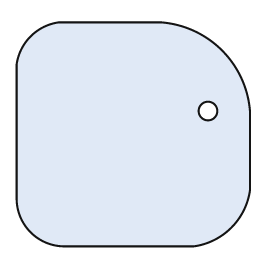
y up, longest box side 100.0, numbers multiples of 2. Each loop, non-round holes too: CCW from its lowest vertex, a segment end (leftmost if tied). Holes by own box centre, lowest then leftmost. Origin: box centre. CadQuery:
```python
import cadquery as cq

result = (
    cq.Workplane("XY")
    .moveTo(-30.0, -48.0)
    .lineTo(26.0, -48.0)
    .threePointArc((42.0, -40.0), (50.0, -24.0))
    .lineTo(50.0, 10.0)
    .threePointArc((38.0, 36.0), (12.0, 48.0))
    .lineTo(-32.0, 48.0)
    .threePointArc((-44.0, 42.0), (-50.0, 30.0))
    .lineTo(-50.0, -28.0)
    .threePointArc((-44.0, -42.0), (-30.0, -48.0))
    .close()
    .moveTo(32.0, 10.0)
    .circle(4.0)
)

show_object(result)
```